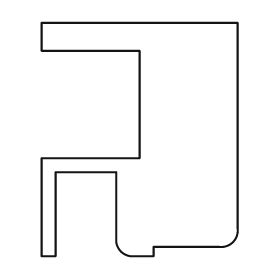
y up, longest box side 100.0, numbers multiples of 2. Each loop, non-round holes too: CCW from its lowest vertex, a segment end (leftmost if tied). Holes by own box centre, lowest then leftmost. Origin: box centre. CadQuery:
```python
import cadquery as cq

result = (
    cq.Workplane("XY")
    .moveTo(-42.0, -50.0)
    .lineTo(-36.0, -50.0)
    .lineTo(-36.0, -14.0)
    .lineTo(-10.0, -14.0)
    .lineTo(-10.0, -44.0)
    .threePointArc((-8.0, -48.0), (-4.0, -50.0))
    .lineTo(6.0, -50.0)
    .lineTo(6.0, -46.0)
    .lineTo(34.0, -46.0)
    .threePointArc((40.0, -44.0), (42.0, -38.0))
    .lineTo(42.0, 50.0)
    .lineTo(-42.0, 50.0)
    .lineTo(-42.0, 38.0)
    .lineTo(0.0, 38.0)
    .lineTo(0.0, -8.0)
    .lineTo(-42.0, -8.0)
    .close()
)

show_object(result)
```